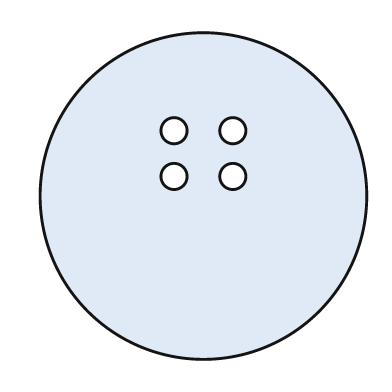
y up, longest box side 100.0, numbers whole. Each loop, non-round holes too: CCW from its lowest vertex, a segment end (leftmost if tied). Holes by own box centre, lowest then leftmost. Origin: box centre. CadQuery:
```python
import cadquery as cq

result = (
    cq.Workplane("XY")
    .moveTo(0.0, 0.0)
    .circle(50.0)
    .moveTo(-9.0, 6.0)
    .circle(4.0)
    .moveTo(9.0, 6.0)
    .circle(4.0)
    .moveTo(-9.0, 20.0)
    .circle(4.0)
    .moveTo(9.0, 20.0)
    .circle(4.0)
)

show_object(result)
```